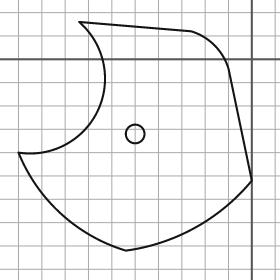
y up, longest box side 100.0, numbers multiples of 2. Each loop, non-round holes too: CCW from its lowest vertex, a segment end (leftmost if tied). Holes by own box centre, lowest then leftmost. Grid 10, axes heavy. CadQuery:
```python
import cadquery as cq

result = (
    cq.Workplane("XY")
    .moveTo(-54.0, -82.0)
    .threePointArc((-24.0, -72.0), (0.0, -52.0))
    .lineTo(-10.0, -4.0)
    .threePointArc((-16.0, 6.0), (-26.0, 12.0))
    .lineTo(-74.0, 16.0)
    .threePointArc((-66.0, -22.0), (-100.0, -40.0))
    .threePointArc((-82.0, -66.0), (-54.0, -82.0))
    .close()
    .moveTo(-50.0, -32.0)
    .circle(4.0)
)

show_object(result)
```